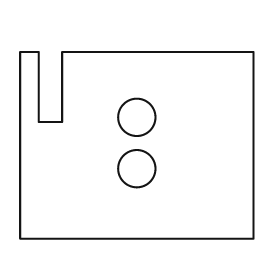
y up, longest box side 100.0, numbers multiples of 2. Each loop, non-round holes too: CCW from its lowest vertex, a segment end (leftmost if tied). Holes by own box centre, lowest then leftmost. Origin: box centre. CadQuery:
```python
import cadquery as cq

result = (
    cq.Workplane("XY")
    .moveTo(-50.0, -40.0)
    .lineTo(50.0, -40.0)
    .lineTo(50.0, 40.0)
    .lineTo(-32.0, 40.0)
    .lineTo(-32.0, 10.0)
    .lineTo(-42.0, 10.0)
    .lineTo(-42.0, 40.0)
    .lineTo(-50.0, 40.0)
    .close()
    .moveTo(0.0, -10.0)
    .circle(8.0)
    .moveTo(0.0, 12.0)
    .circle(8.0)
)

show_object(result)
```